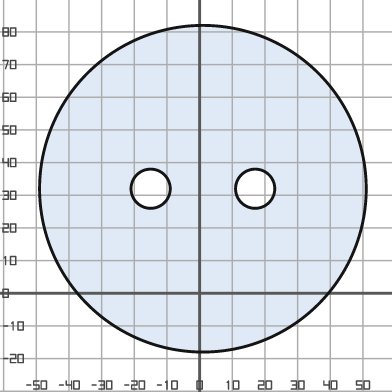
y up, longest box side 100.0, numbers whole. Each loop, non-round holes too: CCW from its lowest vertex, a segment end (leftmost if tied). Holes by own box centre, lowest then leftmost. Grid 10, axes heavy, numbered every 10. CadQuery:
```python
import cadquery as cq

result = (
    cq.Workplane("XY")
    .moveTo(1.0, 32.0)
    .circle(50.0)
    .moveTo(-15.0, 32.0)
    .circle(6.0)
    .moveTo(17.0, 32.0)
    .circle(6.0)
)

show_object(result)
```